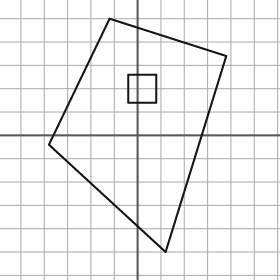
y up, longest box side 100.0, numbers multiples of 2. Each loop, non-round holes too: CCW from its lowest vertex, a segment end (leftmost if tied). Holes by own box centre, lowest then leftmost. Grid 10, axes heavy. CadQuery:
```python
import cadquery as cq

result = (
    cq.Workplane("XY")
    .moveTo(12.0, -50.0)
    .lineTo(38.0, 34.0)
    .lineTo(-12.0, 50.0)
    .lineTo(-38.0, -4.0)
    .close()
    .moveTo(-4.0, 14.0)
    .lineTo(8.0, 14.0)
    .lineTo(8.0, 26.0)
    .lineTo(-4.0, 26.0)
    .close()
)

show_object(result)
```